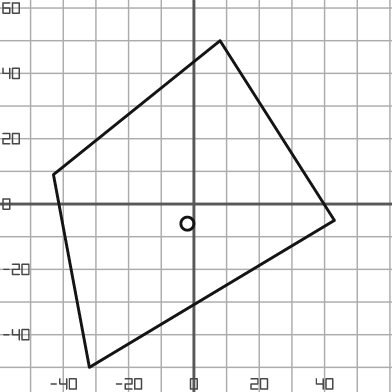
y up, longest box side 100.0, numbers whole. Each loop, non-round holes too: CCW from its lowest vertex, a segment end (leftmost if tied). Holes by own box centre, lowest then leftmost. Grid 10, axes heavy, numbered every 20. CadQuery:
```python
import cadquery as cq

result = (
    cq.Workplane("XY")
    .moveTo(-32.0, -50.0)
    .lineTo(43.0, -5.0)
    .lineTo(8.0, 50.0)
    .lineTo(-43.0, 9.0)
    .close()
    .moveTo(-2.0, -6.0)
    .circle(2.0)
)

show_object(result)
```